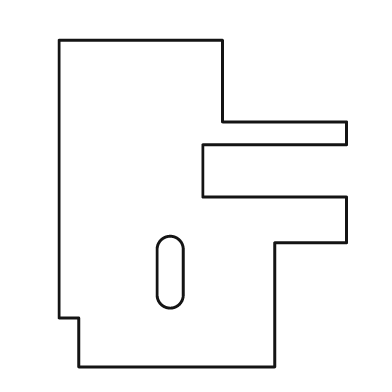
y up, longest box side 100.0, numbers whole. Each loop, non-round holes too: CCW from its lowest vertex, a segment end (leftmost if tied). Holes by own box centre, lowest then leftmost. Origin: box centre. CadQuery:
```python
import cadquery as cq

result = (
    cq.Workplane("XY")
    .moveTo(-38.0, -50.0)
    .lineTo(22.0, -50.0)
    .lineTo(22.0, -12.0)
    .lineTo(44.0, -12.0)
    .lineTo(44.0, 2.0)
    .lineTo(0.0, 2.0)
    .lineTo(0.0, 18.0)
    .lineTo(44.0, 18.0)
    .lineTo(44.0, 25.0)
    .lineTo(6.0, 25.0)
    .lineTo(6.0, 50.0)
    .lineTo(-44.0, 50.0)
    .lineTo(-44.0, -35.0)
    .lineTo(-38.0, -35.0)
    .close()
    .moveTo(-14.0, -28.0)
    .threePointArc((-10.0, -32.0), (-6.0, -28.0))
    .lineTo(-6.0, -14.0)
    .threePointArc((-10.0, -10.0), (-14.0, -14.0))
    .close()
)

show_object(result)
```